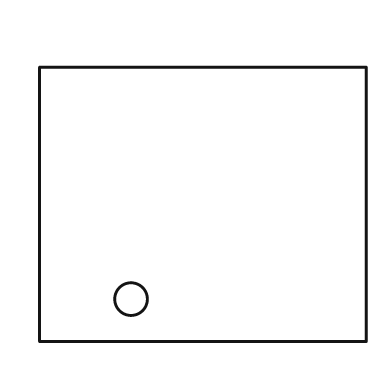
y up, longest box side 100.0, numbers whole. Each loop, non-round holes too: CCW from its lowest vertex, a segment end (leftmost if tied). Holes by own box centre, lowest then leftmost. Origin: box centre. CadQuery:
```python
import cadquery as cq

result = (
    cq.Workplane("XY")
    .moveTo(-50.0, -42.0)
    .lineTo(50.0, -42.0)
    .lineTo(50.0, 42.0)
    .lineTo(-50.0, 42.0)
    .close()
    .moveTo(-22.0, -29.0)
    .circle(5.0)
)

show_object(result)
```